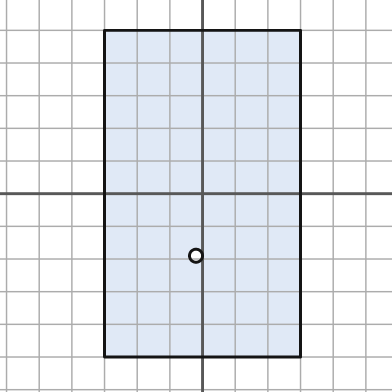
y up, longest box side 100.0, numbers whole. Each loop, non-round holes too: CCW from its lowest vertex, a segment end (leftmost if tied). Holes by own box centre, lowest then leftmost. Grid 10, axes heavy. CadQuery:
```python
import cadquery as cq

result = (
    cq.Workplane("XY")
    .moveTo(-30.0, -50.0)
    .lineTo(30.0, -50.0)
    .lineTo(30.0, 50.0)
    .lineTo(-30.0, 50.0)
    .close()
    .moveTo(-2.0, -19.0)
    .circle(2.0)
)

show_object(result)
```